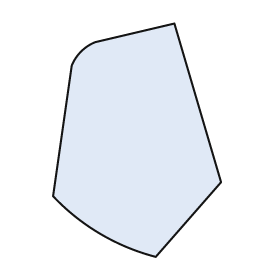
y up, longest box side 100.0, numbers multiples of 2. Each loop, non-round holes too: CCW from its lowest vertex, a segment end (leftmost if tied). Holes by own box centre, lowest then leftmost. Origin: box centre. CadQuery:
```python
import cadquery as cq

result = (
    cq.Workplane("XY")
    .moveTo(8.0, -50.0)
    .lineTo(36.0, -18.0)
    .lineTo(16.0, 50.0)
    .lineTo(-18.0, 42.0)
    .threePointArc((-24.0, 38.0), (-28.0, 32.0))
    .lineTo(-36.0, -24.0)
    .threePointArc((-16.0, -40.0), (8.0, -50.0))
    .close()
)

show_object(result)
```